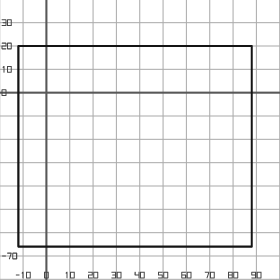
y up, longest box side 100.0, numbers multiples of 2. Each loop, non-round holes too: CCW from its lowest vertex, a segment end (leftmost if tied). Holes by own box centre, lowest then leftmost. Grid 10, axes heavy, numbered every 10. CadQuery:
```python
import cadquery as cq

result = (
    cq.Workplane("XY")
    .moveTo(-12.0, -66.0)
    .lineTo(88.0, -66.0)
    .lineTo(88.0, 20.0)
    .lineTo(-12.0, 20.0)
    .close()
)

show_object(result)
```